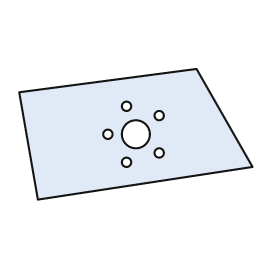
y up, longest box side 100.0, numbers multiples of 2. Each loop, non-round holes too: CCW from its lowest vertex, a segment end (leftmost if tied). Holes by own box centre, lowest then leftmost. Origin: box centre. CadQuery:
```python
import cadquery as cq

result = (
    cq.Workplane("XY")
    .moveTo(-42.0, -28.0)
    .lineTo(50.0, -14.0)
    .lineTo(26.0, 28.0)
    .lineTo(-50.0, 18.0)
    .close()
    .moveTo(-4.0, -12.0)
    .circle(2.0)
    .moveTo(10.0, -8.0)
    .circle(2.0)
    .moveTo(-12.0, 0.0)
    .circle(2.0)
    .moveTo(0.0, 0.0)
    .circle(6.0)
    .moveTo(10.0, 8.0)
    .circle(2.0)
    .moveTo(-4.0, 12.0)
    .circle(2.0)
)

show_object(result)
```